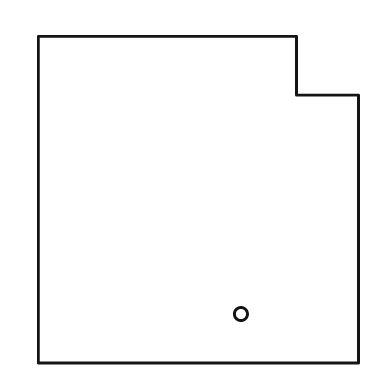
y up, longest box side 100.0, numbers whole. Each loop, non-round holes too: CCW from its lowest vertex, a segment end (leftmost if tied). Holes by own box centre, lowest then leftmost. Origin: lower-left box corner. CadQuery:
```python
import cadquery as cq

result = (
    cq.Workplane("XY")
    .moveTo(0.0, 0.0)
    .lineTo(98.0, 0.0)
    .lineTo(98.0, 82.0)
    .lineTo(79.0, 82.0)
    .lineTo(79.0, 100.0)
    .lineTo(0.0, 100.0)
    .close()
    .moveTo(62.0, 15.0)
    .circle(2.0)
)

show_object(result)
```